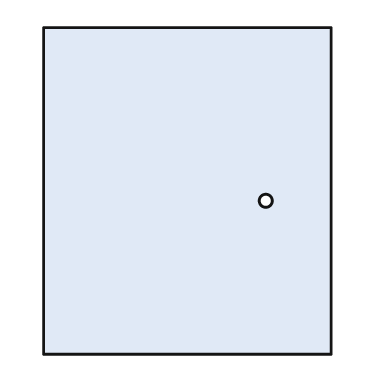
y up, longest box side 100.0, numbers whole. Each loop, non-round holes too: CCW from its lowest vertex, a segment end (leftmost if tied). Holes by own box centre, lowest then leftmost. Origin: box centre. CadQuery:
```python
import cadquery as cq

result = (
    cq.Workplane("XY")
    .moveTo(-44.0, -50.0)
    .lineTo(44.0, -50.0)
    .lineTo(44.0, 50.0)
    .lineTo(-44.0, 50.0)
    .close()
    .moveTo(24.0, -3.0)
    .circle(2.0)
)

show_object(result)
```